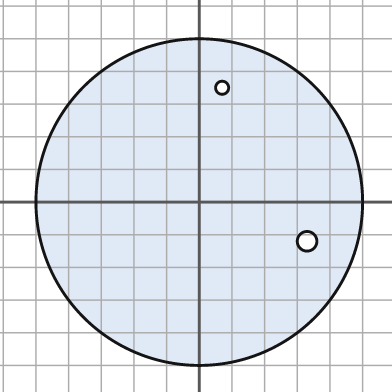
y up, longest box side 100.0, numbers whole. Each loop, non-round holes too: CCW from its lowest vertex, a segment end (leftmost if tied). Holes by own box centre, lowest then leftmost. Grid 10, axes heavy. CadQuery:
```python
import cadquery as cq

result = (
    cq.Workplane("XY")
    .moveTo(0.0, 0.0)
    .circle(50.0)
    .moveTo(33.0, -12.0)
    .circle(3.0)
    .moveTo(7.0, 35.0)
    .circle(2.0)
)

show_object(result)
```